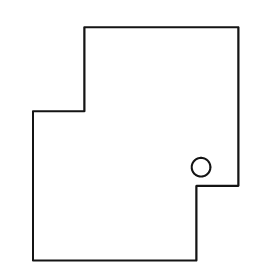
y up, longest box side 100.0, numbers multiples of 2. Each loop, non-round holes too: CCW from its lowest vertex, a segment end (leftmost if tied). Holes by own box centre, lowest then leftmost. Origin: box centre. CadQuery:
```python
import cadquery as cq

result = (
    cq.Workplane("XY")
    .moveTo(-44.0, -50.0)
    .lineTo(26.0, -50.0)
    .lineTo(26.0, -18.0)
    .lineTo(44.0, -18.0)
    .lineTo(44.0, 50.0)
    .lineTo(-22.0, 50.0)
    .lineTo(-22.0, 14.0)
    .lineTo(-44.0, 14.0)
    .close()
    .moveTo(28.0, -10.0)
    .circle(4.0)
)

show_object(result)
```